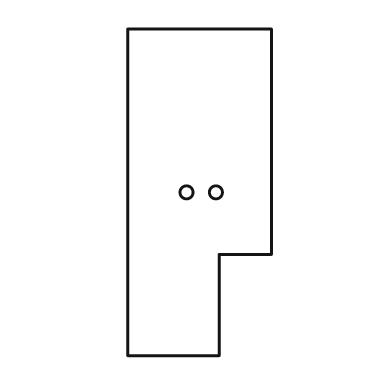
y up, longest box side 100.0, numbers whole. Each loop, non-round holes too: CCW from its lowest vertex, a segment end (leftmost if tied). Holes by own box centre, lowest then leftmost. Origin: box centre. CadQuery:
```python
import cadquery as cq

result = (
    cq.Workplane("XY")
    .moveTo(-22.0, -50.0)
    .lineTo(6.0, -50.0)
    .lineTo(6.0, -19.0)
    .lineTo(22.0, -19.0)
    .lineTo(22.0, 50.0)
    .lineTo(-22.0, 50.0)
    .close()
    .moveTo(-4.0, 0.0)
    .circle(2.0)
    .moveTo(5.0, 0.0)
    .circle(2.0)
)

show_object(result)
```